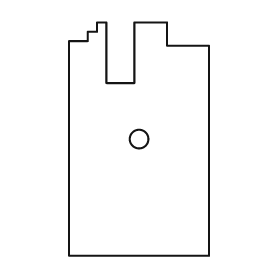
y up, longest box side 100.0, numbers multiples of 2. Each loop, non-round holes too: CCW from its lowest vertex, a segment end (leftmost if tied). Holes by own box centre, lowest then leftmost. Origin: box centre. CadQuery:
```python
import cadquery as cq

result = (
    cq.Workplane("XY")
    .moveTo(-30.0, -50.0)
    .lineTo(30.0, -50.0)
    .lineTo(30.0, 40.0)
    .lineTo(12.0, 40.0)
    .lineTo(12.0, 50.0)
    .lineTo(-2.0, 50.0)
    .lineTo(-2.0, 24.0)
    .lineTo(-14.0, 24.0)
    .lineTo(-14.0, 50.0)
    .lineTo(-18.0, 50.0)
    .lineTo(-18.0, 46.0)
    .lineTo(-22.0, 46.0)
    .lineTo(-22.0, 42.0)
    .lineTo(-30.0, 42.0)
    .close()
    .moveTo(0.0, 0.0)
    .circle(4.0)
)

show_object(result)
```